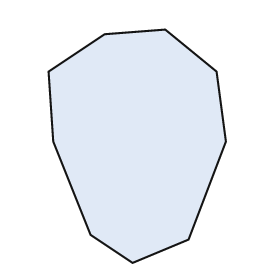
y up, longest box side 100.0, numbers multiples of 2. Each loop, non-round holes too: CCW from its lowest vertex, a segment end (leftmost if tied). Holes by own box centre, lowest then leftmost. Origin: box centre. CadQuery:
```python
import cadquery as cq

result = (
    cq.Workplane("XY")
    .moveTo(-2.0, -50.0)
    .lineTo(22.0, -40.0)
    .lineTo(38.0, 2.0)
    .lineTo(34.0, 32.0)
    .lineTo(12.0, 50.0)
    .lineTo(-14.0, 48.0)
    .lineTo(-38.0, 32.0)
    .lineTo(-36.0, 2.0)
    .lineTo(-20.0, -38.0)
    .close()
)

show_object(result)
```